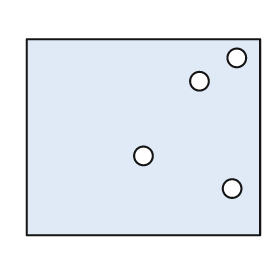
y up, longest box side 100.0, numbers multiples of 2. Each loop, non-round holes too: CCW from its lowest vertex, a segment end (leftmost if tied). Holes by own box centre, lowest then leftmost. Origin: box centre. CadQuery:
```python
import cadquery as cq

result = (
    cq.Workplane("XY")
    .moveTo(-50.0, -42.0)
    .lineTo(50.0, -42.0)
    .lineTo(50.0, 42.0)
    .lineTo(-50.0, 42.0)
    .close()
    .moveTo(38.0, -22.0)
    .circle(4.0)
    .moveTo(0.0, -8.0)
    .circle(4.0)
    .moveTo(24.0, 24.0)
    .circle(4.0)
    .moveTo(40.0, 34.0)
    .circle(4.0)
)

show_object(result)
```